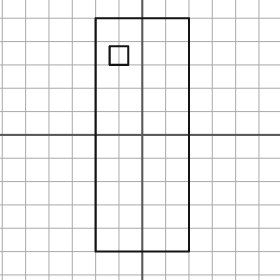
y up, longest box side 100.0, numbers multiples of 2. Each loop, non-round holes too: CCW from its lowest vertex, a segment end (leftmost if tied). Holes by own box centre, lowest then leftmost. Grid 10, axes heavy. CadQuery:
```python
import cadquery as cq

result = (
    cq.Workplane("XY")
    .moveTo(-20.0, -50.0)
    .lineTo(20.0, -50.0)
    .lineTo(20.0, 50.0)
    .lineTo(-20.0, 50.0)
    .close()
    .moveTo(-14.0, 30.0)
    .lineTo(-6.0, 30.0)
    .lineTo(-6.0, 38.0)
    .lineTo(-14.0, 38.0)
    .close()
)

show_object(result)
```